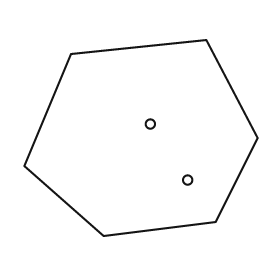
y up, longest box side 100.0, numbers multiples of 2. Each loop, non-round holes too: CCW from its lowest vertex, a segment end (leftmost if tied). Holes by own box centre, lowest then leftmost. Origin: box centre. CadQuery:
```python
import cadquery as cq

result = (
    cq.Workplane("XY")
    .moveTo(-16.0, -42.0)
    .lineTo(32.0, -36.0)
    .lineTo(50.0, 0.0)
    .lineTo(28.0, 42.0)
    .lineTo(-30.0, 36.0)
    .lineTo(-50.0, -12.0)
    .close()
    .moveTo(20.0, -18.0)
    .circle(2.0)
    .moveTo(4.0, 6.0)
    .circle(2.0)
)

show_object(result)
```